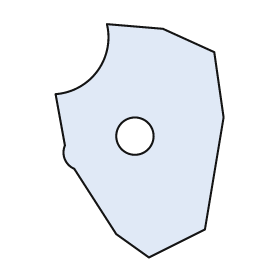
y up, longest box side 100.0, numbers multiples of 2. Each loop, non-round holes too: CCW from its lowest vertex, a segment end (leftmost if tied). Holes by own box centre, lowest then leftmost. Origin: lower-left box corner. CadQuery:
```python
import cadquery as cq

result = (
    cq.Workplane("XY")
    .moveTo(40.0, 0.0)
    .lineTo(64.0, 12.0)
    .lineTo(72.0, 60.0)
    .lineTo(68.0, 88.0)
    .lineTo(46.0, 98.0)
    .lineTo(22.0, 100.0)
    .threePointArc((18.0, 80.0), (0.0, 70.0))
    .lineTo(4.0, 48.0)
    .threePointArc((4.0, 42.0), (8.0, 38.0))
    .lineTo(26.0, 10.0)
    .close()
    .moveTo(34.0, 52.0)
    .circle(8.0)
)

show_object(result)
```